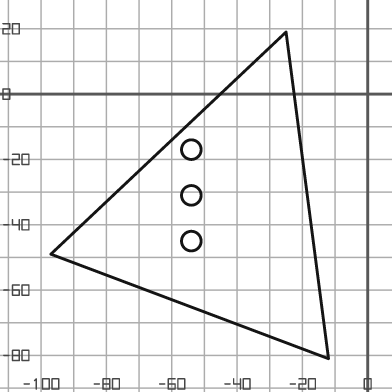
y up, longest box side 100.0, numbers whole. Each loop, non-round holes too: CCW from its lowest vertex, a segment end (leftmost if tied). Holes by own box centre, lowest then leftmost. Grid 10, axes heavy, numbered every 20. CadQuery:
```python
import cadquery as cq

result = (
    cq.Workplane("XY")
    .moveTo(-12.0, -81.0)
    .lineTo(-25.0, 19.0)
    .lineTo(-97.0, -49.0)
    .close()
    .moveTo(-54.0, -45.0)
    .circle(3.0)
    .moveTo(-54.0, -31.0)
    .circle(3.0)
    .moveTo(-54.0, -17.0)
    .circle(3.0)
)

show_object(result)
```